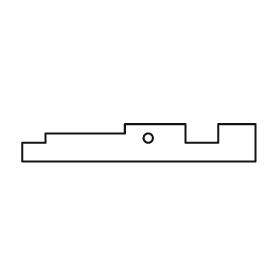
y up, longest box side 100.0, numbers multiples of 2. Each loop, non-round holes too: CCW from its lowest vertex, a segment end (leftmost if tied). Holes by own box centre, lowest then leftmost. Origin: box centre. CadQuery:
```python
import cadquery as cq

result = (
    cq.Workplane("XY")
    .moveTo(-50.0, -8.0)
    .lineTo(50.0, -8.0)
    .lineTo(50.0, 8.0)
    .lineTo(34.0, 8.0)
    .lineTo(34.0, 0.0)
    .lineTo(20.0, 0.0)
    .lineTo(20.0, 8.0)
    .lineTo(-6.0, 8.0)
    .lineTo(-6.0, 4.0)
    .lineTo(-40.0, 4.0)
    .lineTo(-40.0, 0.0)
    .lineTo(-50.0, 0.0)
    .close()
    .moveTo(4.0, 2.0)
    .circle(2.0)
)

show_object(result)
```